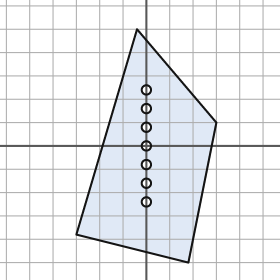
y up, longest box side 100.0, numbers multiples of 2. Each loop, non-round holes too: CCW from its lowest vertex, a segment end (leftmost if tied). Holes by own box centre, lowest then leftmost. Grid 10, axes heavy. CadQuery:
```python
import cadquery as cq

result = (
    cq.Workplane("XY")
    .moveTo(18.0, -50.0)
    .lineTo(30.0, 10.0)
    .lineTo(-4.0, 50.0)
    .lineTo(-30.0, -38.0)
    .close()
    .moveTo(0.0, -24.0)
    .circle(2.0)
    .moveTo(0.0, -16.0)
    .circle(2.0)
    .moveTo(0.0, -8.0)
    .circle(2.0)
    .moveTo(0.0, 0.0)
    .circle(2.0)
    .moveTo(0.0, 8.0)
    .circle(2.0)
    .moveTo(0.0, 16.0)
    .circle(2.0)
    .moveTo(0.0, 24.0)
    .circle(2.0)
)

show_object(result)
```